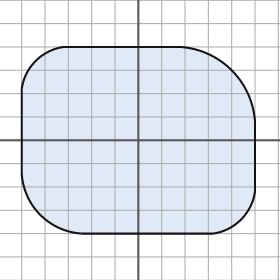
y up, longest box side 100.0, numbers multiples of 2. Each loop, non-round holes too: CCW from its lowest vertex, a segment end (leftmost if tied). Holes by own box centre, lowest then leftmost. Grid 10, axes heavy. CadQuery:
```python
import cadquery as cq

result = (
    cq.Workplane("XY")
    .moveTo(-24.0, -40.0)
    .lineTo(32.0, -40.0)
    .threePointArc((44.0, -34.0), (50.0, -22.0))
    .lineTo(50.0, 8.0)
    .threePointArc((40.0, 30.0), (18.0, 40.0))
    .lineTo(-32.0, 40.0)
    .threePointArc((-44.0, 34.0), (-50.0, 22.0))
    .lineTo(-50.0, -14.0)
    .threePointArc((-42.0, -32.0), (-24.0, -40.0))
    .close()
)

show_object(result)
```